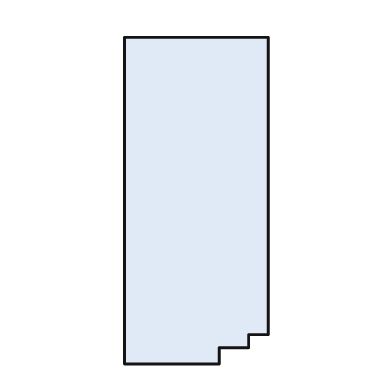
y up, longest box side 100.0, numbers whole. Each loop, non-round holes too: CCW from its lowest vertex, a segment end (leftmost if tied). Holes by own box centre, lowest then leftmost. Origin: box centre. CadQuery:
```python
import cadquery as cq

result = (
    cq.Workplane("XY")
    .moveTo(-22.0, -50.0)
    .lineTo(7.0, -50.0)
    .lineTo(7.0, -45.0)
    .lineTo(16.0, -45.0)
    .lineTo(16.0, -41.0)
    .lineTo(22.0, -41.0)
    .lineTo(22.0, 50.0)
    .lineTo(-22.0, 50.0)
    .close()
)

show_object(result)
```